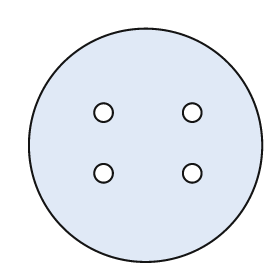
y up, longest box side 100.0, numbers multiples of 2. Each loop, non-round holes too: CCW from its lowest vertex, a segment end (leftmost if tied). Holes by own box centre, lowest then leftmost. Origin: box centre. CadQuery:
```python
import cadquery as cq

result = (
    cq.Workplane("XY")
    .moveTo(0.0, 0.0)
    .circle(50.0)
    .moveTo(-18.0, -12.0)
    .circle(4.0)
    .moveTo(20.0, -12.0)
    .circle(4.0)
    .moveTo(-18.0, 14.0)
    .circle(4.0)
    .moveTo(20.0, 14.0)
    .circle(4.0)
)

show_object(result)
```